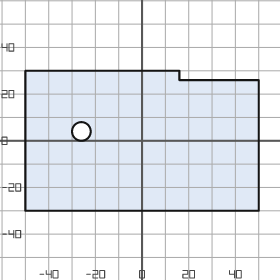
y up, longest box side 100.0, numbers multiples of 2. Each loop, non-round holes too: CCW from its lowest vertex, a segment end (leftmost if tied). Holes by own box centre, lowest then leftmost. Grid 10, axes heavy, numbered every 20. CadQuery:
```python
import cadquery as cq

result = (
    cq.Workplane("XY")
    .moveTo(-50.0, -30.0)
    .lineTo(50.0, -30.0)
    .lineTo(50.0, 26.0)
    .lineTo(16.0, 26.0)
    .lineTo(16.0, 30.0)
    .lineTo(-50.0, 30.0)
    .close()
    .moveTo(-26.0, 4.0)
    .circle(4.0)
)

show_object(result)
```